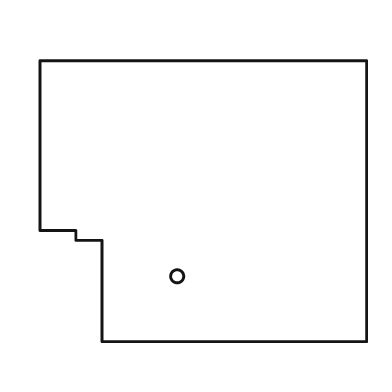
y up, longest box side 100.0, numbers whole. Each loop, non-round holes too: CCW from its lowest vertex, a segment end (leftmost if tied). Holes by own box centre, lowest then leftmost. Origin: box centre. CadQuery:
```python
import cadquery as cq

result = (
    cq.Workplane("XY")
    .moveTo(-31.0, -43.0)
    .lineTo(50.0, -43.0)
    .lineTo(50.0, 43.0)
    .lineTo(-50.0, 43.0)
    .lineTo(-50.0, -9.0)
    .lineTo(-39.0, -9.0)
    .lineTo(-39.0, -12.0)
    .lineTo(-31.0, -12.0)
    .close()
    .moveTo(-8.0, -23.0)
    .circle(2.0)
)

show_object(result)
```